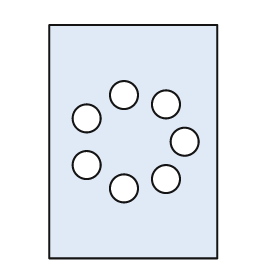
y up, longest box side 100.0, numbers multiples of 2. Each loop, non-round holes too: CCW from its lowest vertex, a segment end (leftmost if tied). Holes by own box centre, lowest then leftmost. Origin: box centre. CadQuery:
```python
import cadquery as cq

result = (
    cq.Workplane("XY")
    .moveTo(-36.0, -50.0)
    .lineTo(36.0, -50.0)
    .lineTo(36.0, 50.0)
    .lineTo(-36.0, 50.0)
    .close()
    .moveTo(-4.0, -20.0)
    .circle(6.0)
    .moveTo(14.0, -16.0)
    .circle(6.0)
    .moveTo(-20.0, -10.0)
    .circle(6.0)
    .moveTo(22.0, 0.0)
    .circle(6.0)
    .moveTo(-20.0, 10.0)
    .circle(6.0)
    .moveTo(14.0, 16.0)
    .circle(6.0)
    .moveTo(-4.0, 20.0)
    .circle(6.0)
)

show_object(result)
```